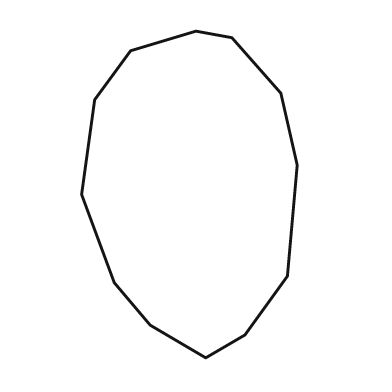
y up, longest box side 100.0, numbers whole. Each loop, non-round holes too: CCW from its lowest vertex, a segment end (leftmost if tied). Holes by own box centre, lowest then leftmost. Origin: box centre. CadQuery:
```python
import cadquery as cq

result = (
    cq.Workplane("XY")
    .moveTo(5.0, -50.0)
    .lineTo(17.0, -43.0)
    .lineTo(30.0, -25.0)
    .lineTo(33.0, 9.0)
    .lineTo(28.0, 31.0)
    .lineTo(13.0, 48.0)
    .lineTo(2.0, 50.0)
    .lineTo(-18.0, 44.0)
    .lineTo(-29.0, 29.0)
    .lineTo(-33.0, 0.0)
    .lineTo(-23.0, -27.0)
    .lineTo(-12.0, -40.0)
    .close()
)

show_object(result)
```